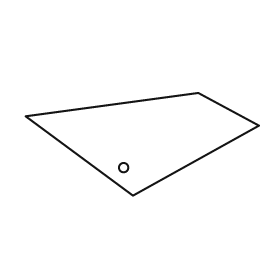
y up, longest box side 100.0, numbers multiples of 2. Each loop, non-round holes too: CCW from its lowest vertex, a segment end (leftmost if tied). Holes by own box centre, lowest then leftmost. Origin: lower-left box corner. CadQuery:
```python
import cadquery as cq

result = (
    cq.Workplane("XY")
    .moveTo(46.0, 0.0)
    .lineTo(100.0, 30.0)
    .lineTo(74.0, 44.0)
    .lineTo(0.0, 34.0)
    .close()
    .moveTo(42.0, 12.0)
    .circle(2.0)
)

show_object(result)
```